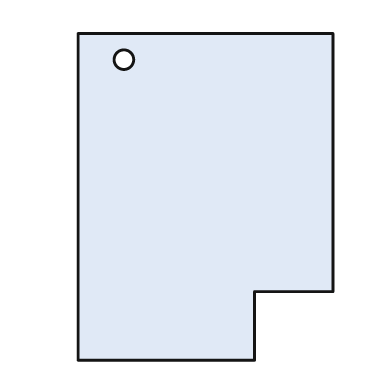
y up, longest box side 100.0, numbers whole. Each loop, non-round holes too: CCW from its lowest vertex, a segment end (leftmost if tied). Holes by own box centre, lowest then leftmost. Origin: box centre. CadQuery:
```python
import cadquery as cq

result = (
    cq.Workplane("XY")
    .moveTo(-39.0, -50.0)
    .lineTo(15.0, -50.0)
    .lineTo(15.0, -29.0)
    .lineTo(39.0, -29.0)
    .lineTo(39.0, 50.0)
    .lineTo(-39.0, 50.0)
    .close()
    .moveTo(-25.0, 42.0)
    .circle(3.0)
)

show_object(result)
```